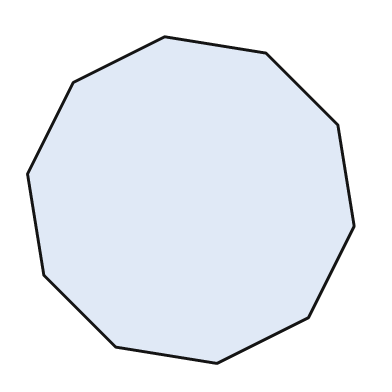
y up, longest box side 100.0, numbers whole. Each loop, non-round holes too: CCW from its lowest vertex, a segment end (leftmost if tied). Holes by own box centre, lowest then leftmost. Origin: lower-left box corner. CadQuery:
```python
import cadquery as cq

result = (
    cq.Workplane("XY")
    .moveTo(58.0, 0.0)
    .lineTo(86.0, 14.0)
    .lineTo(100.0, 42.0)
    .lineTo(95.0, 73.0)
    .lineTo(73.0, 95.0)
    .lineTo(42.0, 100.0)
    .lineTo(14.0, 86.0)
    .lineTo(0.0, 58.0)
    .lineTo(5.0, 27.0)
    .lineTo(27.0, 5.0)
    .close()
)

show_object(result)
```